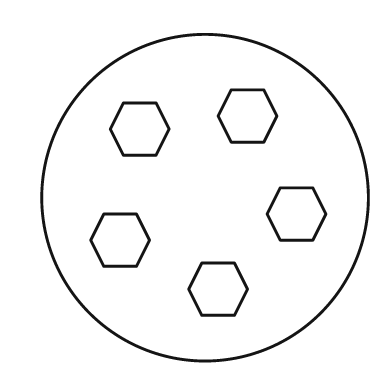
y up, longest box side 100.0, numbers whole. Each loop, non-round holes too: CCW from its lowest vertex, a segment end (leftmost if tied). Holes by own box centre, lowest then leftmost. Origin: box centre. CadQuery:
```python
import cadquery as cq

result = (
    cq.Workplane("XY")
    .moveTo(0.0, 0.0)
    .circle(50.0)
    .moveTo(-1.0, -36.0)
    .lineTo(9.0, -36.0)
    .lineTo(13.0, -28.0)
    .lineTo(9.0, -20.0)
    .lineTo(-1.0, -20.0)
    .lineTo(-5.0, -28.0)
    .close()
    .moveTo(-31.0, -21.0)
    .lineTo(-21.0, -21.0)
    .lineTo(-17.0, -13.0)
    .lineTo(-21.0, -5.0)
    .lineTo(-31.0, -5.0)
    .lineTo(-35.0, -13.0)
    .close()
    .moveTo(23.0, -13.0)
    .lineTo(33.0, -13.0)
    .lineTo(37.0, -5.0)
    .lineTo(33.0, 3.0)
    .lineTo(23.0, 3.0)
    .lineTo(19.0, -5.0)
    .close()
    .moveTo(-25.0, 13.0)
    .lineTo(-15.0, 13.0)
    .lineTo(-11.0, 21.0)
    .lineTo(-15.0, 29.0)
    .lineTo(-25.0, 29.0)
    .lineTo(-29.0, 21.0)
    .close()
    .moveTo(8.0, 17.0)
    .lineTo(18.0, 17.0)
    .lineTo(22.0, 25.0)
    .lineTo(18.0, 33.0)
    .lineTo(8.0, 33.0)
    .lineTo(4.0, 25.0)
    .close()
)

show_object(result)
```